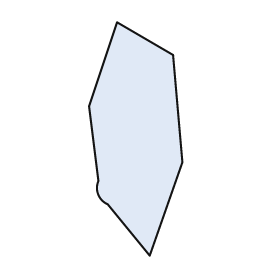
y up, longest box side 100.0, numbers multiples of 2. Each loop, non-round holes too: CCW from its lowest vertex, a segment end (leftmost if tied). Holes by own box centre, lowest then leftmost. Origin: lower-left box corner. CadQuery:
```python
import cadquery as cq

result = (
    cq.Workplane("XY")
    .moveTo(26.0, 0.0)
    .lineTo(40.0, 40.0)
    .lineTo(36.0, 86.0)
    .lineTo(12.0, 100.0)
    .lineTo(0.0, 64.0)
    .lineTo(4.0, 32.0)
    .threePointArc((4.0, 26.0), (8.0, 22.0))
    .close()
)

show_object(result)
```